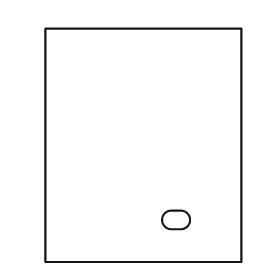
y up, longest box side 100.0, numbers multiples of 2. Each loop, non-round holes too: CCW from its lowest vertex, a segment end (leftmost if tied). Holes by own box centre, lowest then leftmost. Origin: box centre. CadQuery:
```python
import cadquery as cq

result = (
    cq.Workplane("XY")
    .moveTo(-42.0, -50.0)
    .lineTo(42.0, -50.0)
    .lineTo(42.0, 50.0)
    .lineTo(-42.0, 50.0)
    .close()
    .moveTo(12.0, -36.0)
    .lineTo(16.0, -36.0)
    .threePointArc((20.0, -32.0), (16.0, -28.0))
    .lineTo(12.0, -28.0)
    .threePointArc((8.0, -32.0), (12.0, -36.0))
    .close()
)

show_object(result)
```